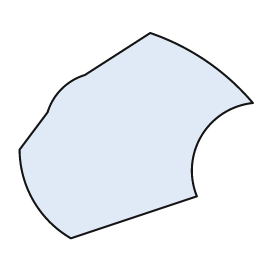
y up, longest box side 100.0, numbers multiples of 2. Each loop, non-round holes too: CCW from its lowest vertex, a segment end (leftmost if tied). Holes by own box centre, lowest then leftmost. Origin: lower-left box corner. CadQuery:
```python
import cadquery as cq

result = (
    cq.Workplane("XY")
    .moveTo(22.0, 0.0)
    .lineTo(76.0, 18.0)
    .threePointArc((78.0, 44.0), (100.0, 58.0))
    .threePointArc((80.0, 76.0), (56.0, 88.0))
    .lineTo(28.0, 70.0)
    .threePointArc((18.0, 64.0), (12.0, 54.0))
    .lineTo(0.0, 38.0)
    .threePointArc((6.0, 16.0), (22.0, 0.0))
    .close()
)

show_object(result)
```